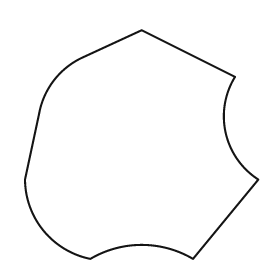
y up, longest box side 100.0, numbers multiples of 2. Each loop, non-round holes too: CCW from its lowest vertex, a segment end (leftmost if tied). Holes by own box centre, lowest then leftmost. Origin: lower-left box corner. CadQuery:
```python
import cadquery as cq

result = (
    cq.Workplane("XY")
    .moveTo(28.0, 0.0)
    .threePointArc((50.0, 6.0), (72.0, 0.0))
    .lineTo(100.0, 34.0)
    .threePointArc((86.0, 54.0), (90.0, 78.0))
    .lineTo(50.0, 98.0)
    .lineTo(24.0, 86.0)
    .threePointArc((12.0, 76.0), (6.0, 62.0))
    .lineTo(0.0, 34.0)
    .threePointArc((8.0, 12.0), (28.0, 0.0))
    .close()
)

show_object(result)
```